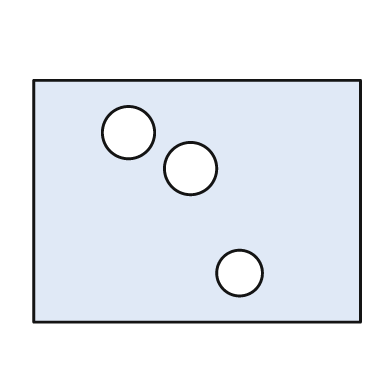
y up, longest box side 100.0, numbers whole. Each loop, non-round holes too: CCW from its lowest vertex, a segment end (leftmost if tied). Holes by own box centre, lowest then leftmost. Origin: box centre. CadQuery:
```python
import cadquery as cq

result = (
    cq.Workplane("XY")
    .moveTo(-50.0, -37.0)
    .lineTo(50.0, -37.0)
    .lineTo(50.0, 37.0)
    .lineTo(-50.0, 37.0)
    .close()
    .moveTo(13.0, -22.0)
    .circle(7.0)
    .moveTo(-2.0, 10.0)
    .circle(8.0)
    .moveTo(-21.0, 21.0)
    .circle(8.0)
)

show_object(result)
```